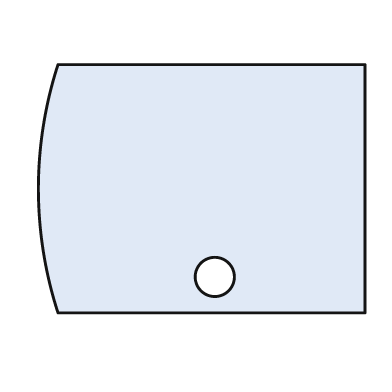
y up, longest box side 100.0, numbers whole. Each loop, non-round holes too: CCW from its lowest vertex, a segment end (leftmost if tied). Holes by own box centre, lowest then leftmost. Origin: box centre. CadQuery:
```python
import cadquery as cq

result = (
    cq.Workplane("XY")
    .moveTo(-44.0, -38.0)
    .lineTo(50.0, -38.0)
    .lineTo(50.0, 38.0)
    .lineTo(-44.0, 38.0)
    .threePointArc((-50.0, 0.0), (-44.0, -38.0))
    .close()
    .moveTo(4.0, -27.0)
    .circle(6.0)
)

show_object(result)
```